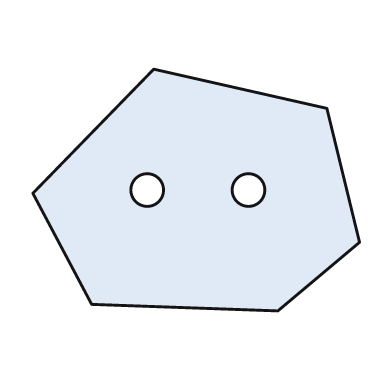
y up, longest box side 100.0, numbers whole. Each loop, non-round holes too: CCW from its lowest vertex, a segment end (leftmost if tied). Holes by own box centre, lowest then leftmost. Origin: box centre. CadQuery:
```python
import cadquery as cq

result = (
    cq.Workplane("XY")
    .moveTo(25.0, -37.0)
    .lineTo(50.0, -16.0)
    .lineTo(40.0, 25.0)
    .lineTo(-13.0, 37.0)
    .lineTo(-50.0, -1.0)
    .lineTo(-32.0, -35.0)
    .close()
    .moveTo(-15.0, 0.0)
    .circle(5.0)
    .moveTo(16.0, 0.0)
    .circle(5.0)
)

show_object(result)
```